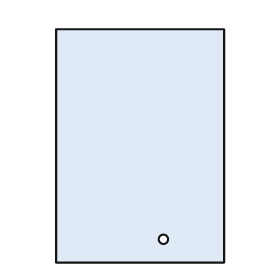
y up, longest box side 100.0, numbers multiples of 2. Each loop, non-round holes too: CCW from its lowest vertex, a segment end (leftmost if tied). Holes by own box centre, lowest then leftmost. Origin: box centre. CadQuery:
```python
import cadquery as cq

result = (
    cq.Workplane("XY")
    .moveTo(-36.0, -50.0)
    .lineTo(36.0, -50.0)
    .lineTo(36.0, 50.0)
    .lineTo(-36.0, 50.0)
    .close()
    .moveTo(10.0, -40.0)
    .circle(2.0)
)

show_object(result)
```